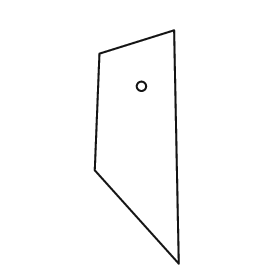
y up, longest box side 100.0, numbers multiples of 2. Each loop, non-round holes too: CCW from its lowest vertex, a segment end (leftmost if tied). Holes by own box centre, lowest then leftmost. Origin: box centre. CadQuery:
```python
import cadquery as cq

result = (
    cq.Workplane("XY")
    .moveTo(18.0, -50.0)
    .lineTo(16.0, 50.0)
    .lineTo(-16.0, 40.0)
    .lineTo(-18.0, -10.0)
    .close()
    .moveTo(2.0, 26.0)
    .circle(2.0)
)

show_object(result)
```